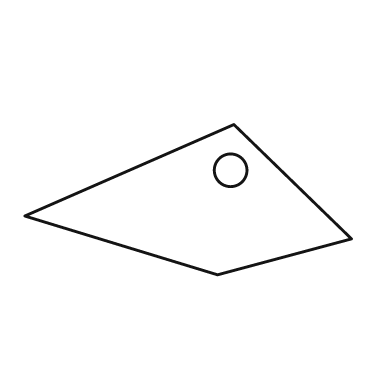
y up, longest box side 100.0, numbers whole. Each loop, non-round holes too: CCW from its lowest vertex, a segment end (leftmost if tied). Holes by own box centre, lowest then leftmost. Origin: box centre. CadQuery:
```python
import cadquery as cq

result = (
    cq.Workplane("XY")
    .moveTo(9.0, -23.0)
    .lineTo(50.0, -12.0)
    .lineTo(14.0, 23.0)
    .lineTo(-50.0, -5.0)
    .close()
    .moveTo(13.0, 9.0)
    .circle(5.0)
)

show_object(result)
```